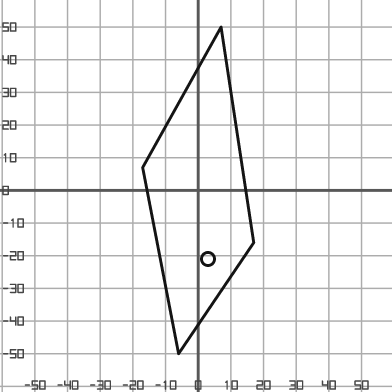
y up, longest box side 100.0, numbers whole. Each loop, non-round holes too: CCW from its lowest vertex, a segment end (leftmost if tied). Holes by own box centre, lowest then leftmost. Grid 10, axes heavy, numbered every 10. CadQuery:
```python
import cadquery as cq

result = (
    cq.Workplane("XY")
    .moveTo(-6.0, -50.0)
    .lineTo(17.0, -16.0)
    .lineTo(7.0, 50.0)
    .lineTo(-17.0, 7.0)
    .close()
    .moveTo(3.0, -21.0)
    .circle(2.0)
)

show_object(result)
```